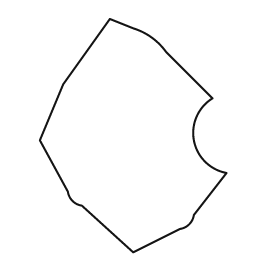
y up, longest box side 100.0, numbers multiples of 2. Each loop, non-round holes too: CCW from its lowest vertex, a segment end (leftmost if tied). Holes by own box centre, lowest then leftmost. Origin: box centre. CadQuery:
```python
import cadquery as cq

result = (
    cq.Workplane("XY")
    .moveTo(0.0, -50.0)
    .lineTo(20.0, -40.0)
    .threePointArc((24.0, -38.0), (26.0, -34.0))
    .lineTo(40.0, -16.0)
    .threePointArc((26.0, -2.0), (34.0, 16.0))
    .lineTo(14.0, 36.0)
    .threePointArc((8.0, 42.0), (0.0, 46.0))
    .lineTo(-10.0, 50.0)
    .lineTo(-30.0, 22.0)
    .lineTo(-40.0, -2.0)
    .lineTo(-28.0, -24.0)
    .threePointArc((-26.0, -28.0), (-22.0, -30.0))
    .close()
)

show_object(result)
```